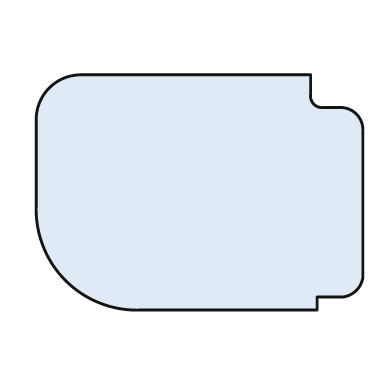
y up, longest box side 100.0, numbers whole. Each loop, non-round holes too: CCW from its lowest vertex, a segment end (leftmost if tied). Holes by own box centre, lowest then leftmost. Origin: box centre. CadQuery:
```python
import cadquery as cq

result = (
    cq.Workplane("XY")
    .moveTo(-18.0, -36.0)
    .lineTo(36.0, -36.0)
    .lineTo(36.0, -32.0)
    .lineTo(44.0, -32.0)
    .threePointArc((48.0, -30.0), (50.0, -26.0))
    .lineTo(50.0, 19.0)
    .threePointArc((48.0, 24.0), (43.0, 26.0))
    .lineTo(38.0, 26.0)
    .threePointArc((35.0, 27.0), (34.0, 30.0))
    .lineTo(34.0, 36.0)
    .lineTo(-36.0, 36.0)
    .threePointArc((-46.0, 32.0), (-50.0, 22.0))
    .lineTo(-50.0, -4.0)
    .threePointArc((-41.0, -27.0), (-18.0, -36.0))
    .close()
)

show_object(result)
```